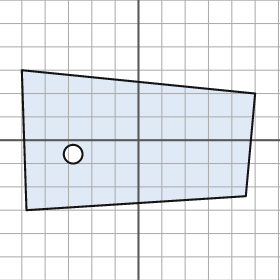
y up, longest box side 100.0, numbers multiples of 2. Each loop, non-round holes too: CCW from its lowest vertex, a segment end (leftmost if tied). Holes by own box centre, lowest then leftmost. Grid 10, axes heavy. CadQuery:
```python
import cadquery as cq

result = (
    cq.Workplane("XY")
    .moveTo(-48.0, -30.0)
    .lineTo(46.0, -24.0)
    .lineTo(50.0, 20.0)
    .lineTo(-50.0, 30.0)
    .close()
    .moveTo(-28.0, -6.0)
    .circle(4.0)
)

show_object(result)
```